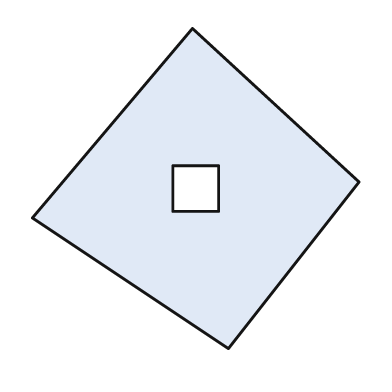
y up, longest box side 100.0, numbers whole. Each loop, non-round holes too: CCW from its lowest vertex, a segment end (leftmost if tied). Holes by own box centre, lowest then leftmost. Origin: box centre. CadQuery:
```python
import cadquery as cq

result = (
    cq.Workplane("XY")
    .moveTo(10.0, -49.0)
    .lineTo(50.0, 2.0)
    .lineTo(-1.0, 49.0)
    .lineTo(-50.0, -9.0)
    .close()
    .moveTo(-7.0, -7.0)
    .lineTo(7.0, -7.0)
    .lineTo(7.0, 7.0)
    .lineTo(-7.0, 7.0)
    .close()
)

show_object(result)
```